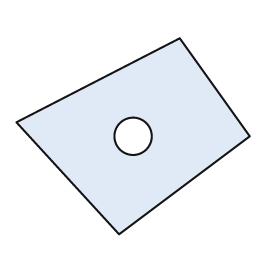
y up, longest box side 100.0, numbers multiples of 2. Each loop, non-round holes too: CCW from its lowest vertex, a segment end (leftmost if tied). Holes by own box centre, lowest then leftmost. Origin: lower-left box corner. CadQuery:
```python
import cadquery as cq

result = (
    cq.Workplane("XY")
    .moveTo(44.0, 0.0)
    .lineTo(100.0, 42.0)
    .lineTo(70.0, 84.0)
    .lineTo(0.0, 48.0)
    .close()
    .moveTo(50.0, 42.0)
    .circle(8.0)
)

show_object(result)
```